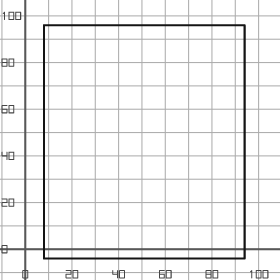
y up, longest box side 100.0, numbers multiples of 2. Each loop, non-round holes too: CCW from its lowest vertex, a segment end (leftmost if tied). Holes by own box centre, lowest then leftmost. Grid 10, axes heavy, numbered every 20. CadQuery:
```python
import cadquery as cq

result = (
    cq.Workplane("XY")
    .moveTo(8.0, -4.0)
    .lineTo(94.0, -4.0)
    .lineTo(94.0, 96.0)
    .lineTo(8.0, 96.0)
    .close()
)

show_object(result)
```